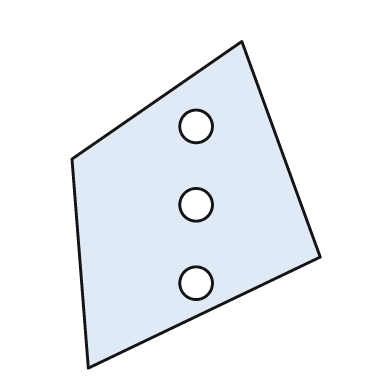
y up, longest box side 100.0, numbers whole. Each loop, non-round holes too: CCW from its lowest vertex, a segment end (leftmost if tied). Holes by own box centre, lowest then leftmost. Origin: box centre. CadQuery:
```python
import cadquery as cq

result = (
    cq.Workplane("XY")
    .moveTo(-33.0, -50.0)
    .lineTo(38.0, -16.0)
    .lineTo(14.0, 50.0)
    .lineTo(-38.0, 14.0)
    .close()
    .moveTo(0.0, -24.0)
    .circle(5.0)
    .moveTo(0.0, 0.0)
    .circle(5.0)
    .moveTo(0.0, 24.0)
    .circle(5.0)
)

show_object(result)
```